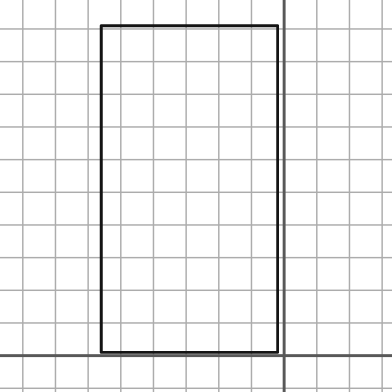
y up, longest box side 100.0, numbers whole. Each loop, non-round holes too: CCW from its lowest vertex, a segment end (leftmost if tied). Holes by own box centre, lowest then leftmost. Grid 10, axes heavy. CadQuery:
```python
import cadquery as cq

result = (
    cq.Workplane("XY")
    .moveTo(-56.0, 1.0)
    .lineTo(-2.0, 1.0)
    .lineTo(-2.0, 101.0)
    .lineTo(-56.0, 101.0)
    .close()
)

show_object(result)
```